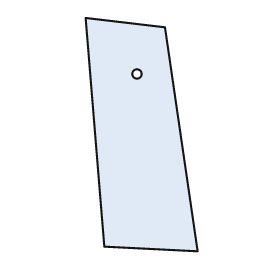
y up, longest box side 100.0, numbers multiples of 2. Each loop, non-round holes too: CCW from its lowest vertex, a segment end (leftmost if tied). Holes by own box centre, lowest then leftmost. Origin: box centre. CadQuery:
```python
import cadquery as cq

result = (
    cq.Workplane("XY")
    .moveTo(24.0, -50.0)
    .lineTo(10.0, 46.0)
    .lineTo(-24.0, 50.0)
    .lineTo(-16.0, -48.0)
    .close()
    .moveTo(-2.0, 26.0)
    .circle(2.0)
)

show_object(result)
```